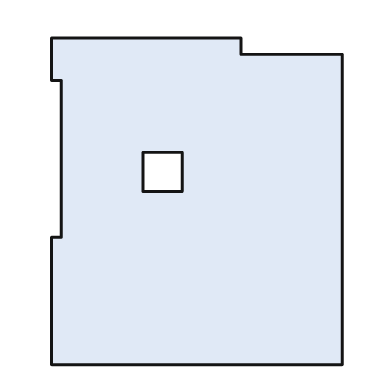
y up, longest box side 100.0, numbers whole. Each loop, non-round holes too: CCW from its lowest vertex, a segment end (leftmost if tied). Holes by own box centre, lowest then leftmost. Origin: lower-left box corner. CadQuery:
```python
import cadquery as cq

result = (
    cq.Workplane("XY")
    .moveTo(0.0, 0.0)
    .lineTo(89.0, 0.0)
    .lineTo(89.0, 95.0)
    .lineTo(58.0, 95.0)
    .lineTo(58.0, 100.0)
    .lineTo(0.0, 100.0)
    .lineTo(0.0, 87.0)
    .lineTo(3.0, 87.0)
    .lineTo(3.0, 39.0)
    .lineTo(0.0, 39.0)
    .close()
    .moveTo(28.0, 53.0)
    .lineTo(40.0, 53.0)
    .lineTo(40.0, 65.0)
    .lineTo(28.0, 65.0)
    .close()
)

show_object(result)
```